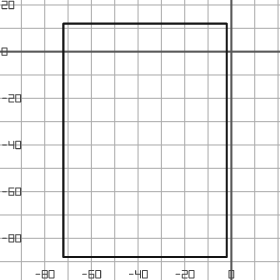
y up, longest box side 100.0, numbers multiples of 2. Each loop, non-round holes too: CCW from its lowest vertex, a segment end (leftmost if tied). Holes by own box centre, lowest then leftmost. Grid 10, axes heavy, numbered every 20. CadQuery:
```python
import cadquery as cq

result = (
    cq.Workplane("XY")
    .moveTo(-72.0, -88.0)
    .lineTo(-2.0, -88.0)
    .lineTo(-2.0, 12.0)
    .lineTo(-72.0, 12.0)
    .close()
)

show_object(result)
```